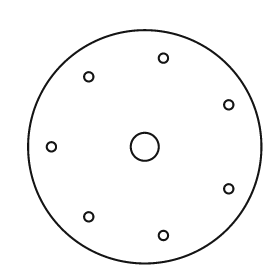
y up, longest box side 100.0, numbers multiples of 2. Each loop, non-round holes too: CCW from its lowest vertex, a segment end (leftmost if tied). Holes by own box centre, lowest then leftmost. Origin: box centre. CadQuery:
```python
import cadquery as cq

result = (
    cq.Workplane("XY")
    .moveTo(0.0, 0.0)
    .circle(50.0)
    .moveTo(8.0, -38.0)
    .circle(2.0)
    .moveTo(-24.0, -30.0)
    .circle(2.0)
    .moveTo(36.0, -18.0)
    .circle(2.0)
    .moveTo(-40.0, 0.0)
    .circle(2.0)
    .moveTo(0.0, 0.0)
    .circle(6.0)
    .moveTo(36.0, 18.0)
    .circle(2.0)
    .moveTo(-24.0, 30.0)
    .circle(2.0)
    .moveTo(8.0, 38.0)
    .circle(2.0)
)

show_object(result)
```